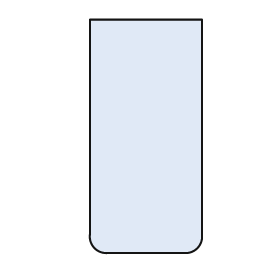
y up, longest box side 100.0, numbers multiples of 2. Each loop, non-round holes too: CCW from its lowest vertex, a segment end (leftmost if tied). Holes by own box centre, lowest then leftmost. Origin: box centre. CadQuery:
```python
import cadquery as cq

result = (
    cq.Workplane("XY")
    .moveTo(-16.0, -50.0)
    .lineTo(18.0, -50.0)
    .threePointArc((22.0, -48.0), (24.0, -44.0))
    .lineTo(24.0, 50.0)
    .lineTo(-24.0, 50.0)
    .lineTo(-24.0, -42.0)
    .threePointArc((-22.0, -48.0), (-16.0, -50.0))
    .close()
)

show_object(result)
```